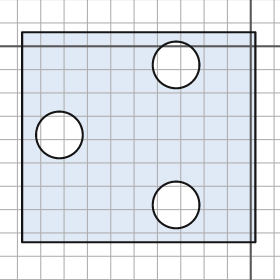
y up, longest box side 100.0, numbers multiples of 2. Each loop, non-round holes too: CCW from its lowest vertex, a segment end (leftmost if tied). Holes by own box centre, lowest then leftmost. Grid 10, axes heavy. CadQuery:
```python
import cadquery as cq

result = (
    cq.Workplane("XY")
    .moveTo(-98.0, -84.0)
    .lineTo(2.0, -84.0)
    .lineTo(2.0, 6.0)
    .lineTo(-98.0, 6.0)
    .close()
    .moveTo(-32.0, -68.0)
    .circle(10.0)
    .moveTo(-82.0, -38.0)
    .circle(10.0)
    .moveTo(-32.0, -8.0)
    .circle(10.0)
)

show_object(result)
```